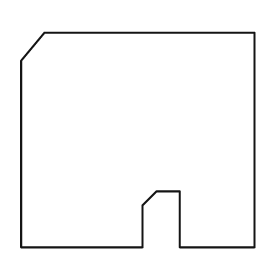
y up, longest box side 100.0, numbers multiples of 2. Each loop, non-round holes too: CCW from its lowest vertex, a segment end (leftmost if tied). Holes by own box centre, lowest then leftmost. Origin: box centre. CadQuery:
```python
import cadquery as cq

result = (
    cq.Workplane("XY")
    .moveTo(-50.0, -46.0)
    .lineTo(2.0, -46.0)
    .lineTo(2.0, -28.0)
    .lineTo(8.0, -22.0)
    .lineTo(18.0, -22.0)
    .lineTo(18.0, -46.0)
    .lineTo(50.0, -46.0)
    .lineTo(50.0, 46.0)
    .lineTo(-40.0, 46.0)
    .lineTo(-50.0, 34.0)
    .close()
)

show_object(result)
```